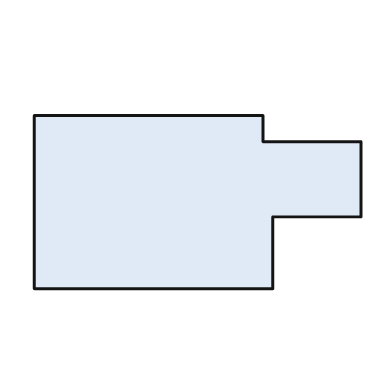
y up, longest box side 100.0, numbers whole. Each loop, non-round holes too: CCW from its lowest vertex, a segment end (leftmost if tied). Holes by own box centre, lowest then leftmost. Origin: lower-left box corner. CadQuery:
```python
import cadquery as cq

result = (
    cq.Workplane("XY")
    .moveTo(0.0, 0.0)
    .lineTo(73.0, 0.0)
    .lineTo(73.0, 22.0)
    .lineTo(100.0, 22.0)
    .lineTo(100.0, 45.0)
    .lineTo(70.0, 45.0)
    .lineTo(70.0, 53.0)
    .lineTo(0.0, 53.0)
    .close()
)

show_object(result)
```